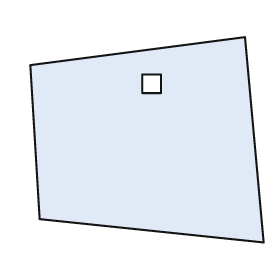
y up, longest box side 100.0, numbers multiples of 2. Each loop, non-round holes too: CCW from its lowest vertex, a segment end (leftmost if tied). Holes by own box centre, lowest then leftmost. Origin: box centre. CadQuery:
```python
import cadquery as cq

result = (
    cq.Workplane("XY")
    .moveTo(50.0, -44.0)
    .lineTo(42.0, 44.0)
    .lineTo(-50.0, 32.0)
    .lineTo(-46.0, -34.0)
    .close()
    .moveTo(-2.0, 20.0)
    .lineTo(6.0, 20.0)
    .lineTo(6.0, 28.0)
    .lineTo(-2.0, 28.0)
    .close()
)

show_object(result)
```